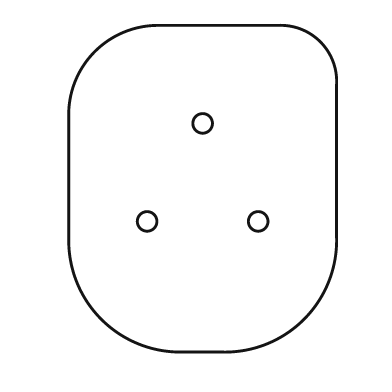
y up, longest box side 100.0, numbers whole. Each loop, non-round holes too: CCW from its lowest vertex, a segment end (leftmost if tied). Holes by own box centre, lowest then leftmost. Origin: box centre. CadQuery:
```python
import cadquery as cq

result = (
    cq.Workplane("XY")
    .moveTo(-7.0, -50.0)
    .lineTo(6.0, -50.0)
    .threePointArc((31.0, -40.0), (41.0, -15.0))
    .lineTo(41.0, 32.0)
    .threePointArc((36.0, 45.0), (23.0, 50.0))
    .lineTo(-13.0, 50.0)
    .threePointArc((-33.0, 42.0), (-41.0, 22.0))
    .lineTo(-41.0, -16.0)
    .threePointArc((-31.0, -40.0), (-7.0, -50.0))
    .close()
    .moveTo(-17.0, -10.0)
    .circle(3.0)
    .moveTo(17.0, -10.0)
    .circle(3.0)
    .moveTo(0.0, 20.0)
    .circle(3.0)
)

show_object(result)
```